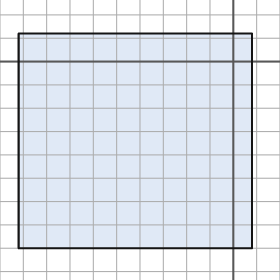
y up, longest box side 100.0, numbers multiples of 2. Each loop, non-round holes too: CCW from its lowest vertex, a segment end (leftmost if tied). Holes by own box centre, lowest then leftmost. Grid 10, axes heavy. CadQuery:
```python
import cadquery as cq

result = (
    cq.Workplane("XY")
    .moveTo(-92.0, -80.0)
    .lineTo(8.0, -80.0)
    .lineTo(8.0, 12.0)
    .lineTo(-92.0, 12.0)
    .close()
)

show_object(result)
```